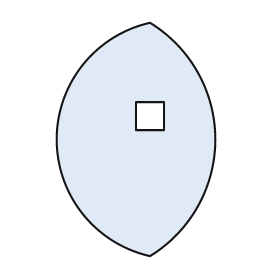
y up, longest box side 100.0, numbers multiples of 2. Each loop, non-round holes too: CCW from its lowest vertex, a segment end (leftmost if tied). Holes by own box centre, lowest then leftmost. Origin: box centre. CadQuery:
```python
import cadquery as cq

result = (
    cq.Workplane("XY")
    .moveTo(6.0, -50.0)
    .threePointArc((34.0, 0.0), (6.0, 50.0))
    .threePointArc((-34.0, 0.0), (6.0, -50.0))
    .close()
    .moveTo(0.0, 4.0)
    .lineTo(12.0, 4.0)
    .lineTo(12.0, 16.0)
    .lineTo(0.0, 16.0)
    .close()
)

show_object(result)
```